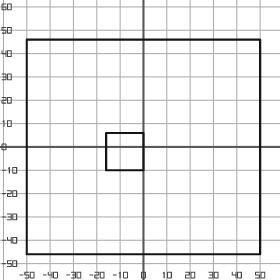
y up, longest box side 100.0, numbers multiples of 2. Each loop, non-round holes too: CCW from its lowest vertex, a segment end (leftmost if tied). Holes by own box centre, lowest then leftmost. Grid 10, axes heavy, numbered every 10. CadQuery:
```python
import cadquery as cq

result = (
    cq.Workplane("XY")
    .moveTo(-50.0, -46.0)
    .lineTo(50.0, -46.0)
    .lineTo(50.0, 46.0)
    .lineTo(-50.0, 46.0)
    .close()
    .moveTo(-16.0, -10.0)
    .lineTo(0.0, -10.0)
    .lineTo(0.0, 6.0)
    .lineTo(-16.0, 6.0)
    .close()
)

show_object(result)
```